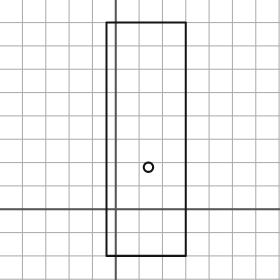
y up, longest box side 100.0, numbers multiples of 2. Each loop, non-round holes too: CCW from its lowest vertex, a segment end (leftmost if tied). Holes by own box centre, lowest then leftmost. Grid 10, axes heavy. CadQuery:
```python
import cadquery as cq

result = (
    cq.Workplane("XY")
    .moveTo(-4.0, -20.0)
    .lineTo(30.0, -20.0)
    .lineTo(30.0, 80.0)
    .lineTo(-4.0, 80.0)
    .close()
    .moveTo(14.0, 18.0)
    .circle(2.0)
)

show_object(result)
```